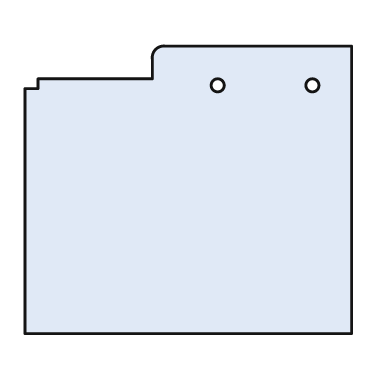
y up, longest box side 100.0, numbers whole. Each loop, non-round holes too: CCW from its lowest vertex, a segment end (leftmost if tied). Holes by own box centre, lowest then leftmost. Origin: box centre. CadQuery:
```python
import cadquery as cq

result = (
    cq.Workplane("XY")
    .moveTo(-50.0, -44.0)
    .lineTo(50.0, -44.0)
    .lineTo(50.0, 44.0)
    .lineTo(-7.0, 44.0)
    .threePointArc((-10.0, 43.0), (-11.0, 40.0))
    .lineTo(-11.0, 34.0)
    .lineTo(-46.0, 34.0)
    .lineTo(-46.0, 31.0)
    .lineTo(-50.0, 31.0)
    .close()
    .moveTo(9.0, 32.0)
    .circle(2.0)
    .moveTo(38.0, 32.0)
    .circle(2.0)
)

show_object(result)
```